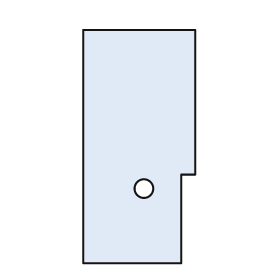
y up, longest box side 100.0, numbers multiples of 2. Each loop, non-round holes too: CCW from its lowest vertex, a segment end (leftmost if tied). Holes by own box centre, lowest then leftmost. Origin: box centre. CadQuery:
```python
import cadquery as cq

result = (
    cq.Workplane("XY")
    .moveTo(-24.0, -50.0)
    .lineTo(18.0, -50.0)
    .lineTo(18.0, -12.0)
    .lineTo(24.0, -12.0)
    .lineTo(24.0, 50.0)
    .lineTo(-24.0, 50.0)
    .close()
    .moveTo(2.0, -18.0)
    .circle(4.0)
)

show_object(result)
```